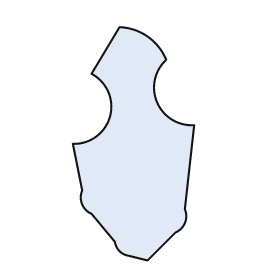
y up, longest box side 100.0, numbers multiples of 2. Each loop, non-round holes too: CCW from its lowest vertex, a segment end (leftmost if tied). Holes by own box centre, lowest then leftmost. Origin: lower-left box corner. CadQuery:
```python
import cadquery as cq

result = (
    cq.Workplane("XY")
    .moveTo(32.0, 0.0)
    .lineTo(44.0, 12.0)
    .threePointArc((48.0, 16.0), (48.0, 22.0))
    .lineTo(52.0, 58.0)
    .threePointArc((36.0, 68.0), (40.0, 86.0))
    .threePointArc((32.0, 96.0), (20.0, 100.0))
    .lineTo(8.0, 80.0)
    .threePointArc((16.0, 62.0), (0.0, 50.0))
    .lineTo(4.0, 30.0)
    .threePointArc((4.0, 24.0), (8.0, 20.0))
    .lineTo(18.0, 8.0)
    .threePointArc((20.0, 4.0), (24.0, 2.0))
    .close()
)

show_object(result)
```